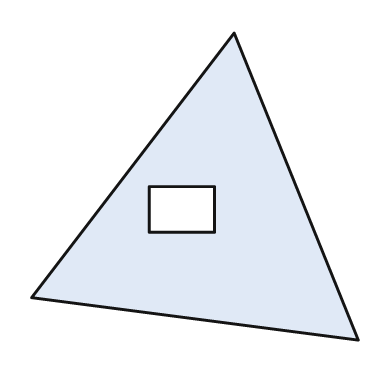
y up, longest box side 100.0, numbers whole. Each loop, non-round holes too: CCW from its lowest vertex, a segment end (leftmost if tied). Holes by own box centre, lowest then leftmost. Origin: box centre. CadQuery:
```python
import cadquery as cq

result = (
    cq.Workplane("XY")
    .moveTo(50.0, -47.0)
    .lineTo(12.0, 47.0)
    .lineTo(-50.0, -34.0)
    .close()
    .moveTo(-14.0, -14.0)
    .lineTo(6.0, -14.0)
    .lineTo(6.0, 0.0)
    .lineTo(-14.0, 0.0)
    .close()
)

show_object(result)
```